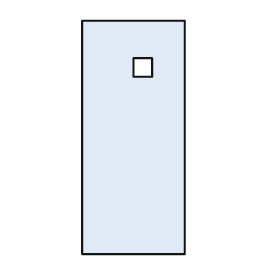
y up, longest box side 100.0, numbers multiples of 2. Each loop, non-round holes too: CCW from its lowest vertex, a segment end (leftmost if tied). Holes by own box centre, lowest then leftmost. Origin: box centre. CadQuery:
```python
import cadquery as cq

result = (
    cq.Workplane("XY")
    .moveTo(-22.0, -50.0)
    .lineTo(22.0, -50.0)
    .lineTo(22.0, 50.0)
    .lineTo(-22.0, 50.0)
    .close()
    .moveTo(0.0, 26.0)
    .lineTo(8.0, 26.0)
    .lineTo(8.0, 34.0)
    .lineTo(0.0, 34.0)
    .close()
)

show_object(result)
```